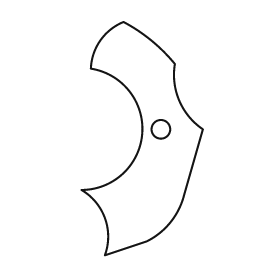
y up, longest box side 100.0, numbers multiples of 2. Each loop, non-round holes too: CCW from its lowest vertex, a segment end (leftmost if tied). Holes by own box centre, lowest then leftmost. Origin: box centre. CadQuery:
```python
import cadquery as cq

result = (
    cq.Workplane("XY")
    .moveTo(-16.0, -50.0)
    .lineTo(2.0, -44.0)
    .threePointArc((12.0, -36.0), (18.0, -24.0))
    .lineTo(26.0, 4.0)
    .threePointArc((16.0, 16.0), (14.0, 32.0))
    .threePointArc((4.0, 42.0), (-8.0, 50.0))
    .threePointArc((-18.0, 42.0), (-22.0, 30.0))
    .threePointArc((0.0, 2.0), (-26.0, -22.0))
    .threePointArc((-16.0, -34.0), (-16.0, -50.0))
    .close()
    .moveTo(8.0, 4.0)
    .circle(4.0)
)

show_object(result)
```